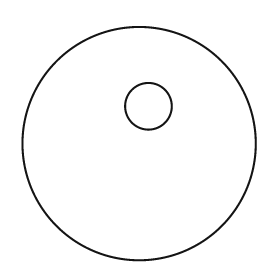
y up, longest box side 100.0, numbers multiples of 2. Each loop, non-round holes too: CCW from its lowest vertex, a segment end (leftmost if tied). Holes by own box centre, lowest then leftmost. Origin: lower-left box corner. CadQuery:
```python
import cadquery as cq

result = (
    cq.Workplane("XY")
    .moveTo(50.0, 50.0)
    .circle(50.0)
    .moveTo(54.0, 66.0)
    .circle(10.0)
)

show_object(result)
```